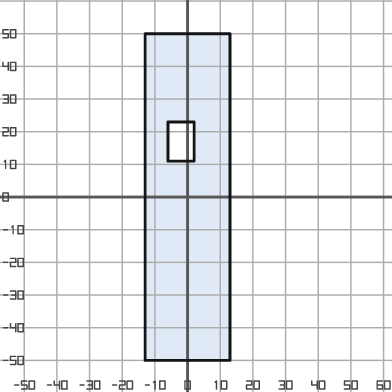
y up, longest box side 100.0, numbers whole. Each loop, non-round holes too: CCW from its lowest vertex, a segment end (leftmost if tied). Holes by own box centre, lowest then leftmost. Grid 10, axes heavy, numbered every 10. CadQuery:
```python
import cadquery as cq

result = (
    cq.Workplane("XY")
    .moveTo(-13.0, -50.0)
    .lineTo(13.0, -50.0)
    .lineTo(13.0, 50.0)
    .lineTo(-13.0, 50.0)
    .close()
    .moveTo(-6.0, 11.0)
    .lineTo(2.0, 11.0)
    .lineTo(2.0, 23.0)
    .lineTo(-6.0, 23.0)
    .close()
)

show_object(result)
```